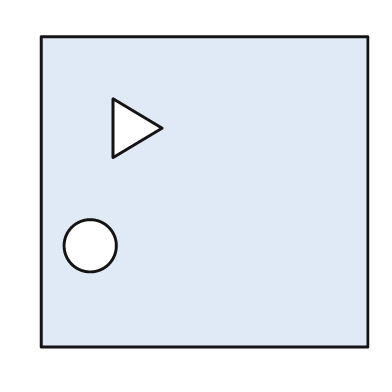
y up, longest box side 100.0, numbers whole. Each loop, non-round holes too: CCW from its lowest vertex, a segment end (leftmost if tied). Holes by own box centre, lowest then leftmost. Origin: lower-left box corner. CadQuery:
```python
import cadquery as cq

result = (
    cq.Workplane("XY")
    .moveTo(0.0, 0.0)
    .lineTo(100.0, 0.0)
    .lineTo(100.0, 95.0)
    .lineTo(0.0, 95.0)
    .close()
    .moveTo(15.0, 31.0)
    .circle(8.0)
    .moveTo(22.0, 58.0)
    .lineTo(37.0, 67.0)
    .lineTo(22.0, 76.0)
    .close()
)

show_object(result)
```